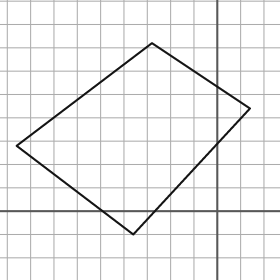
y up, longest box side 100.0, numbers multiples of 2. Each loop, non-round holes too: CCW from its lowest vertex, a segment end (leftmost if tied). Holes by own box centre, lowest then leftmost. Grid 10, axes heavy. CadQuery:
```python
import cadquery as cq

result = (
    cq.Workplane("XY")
    .moveTo(-36.0, -10.0)
    .lineTo(14.0, 44.0)
    .lineTo(-28.0, 72.0)
    .lineTo(-86.0, 28.0)
    .close()
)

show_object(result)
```